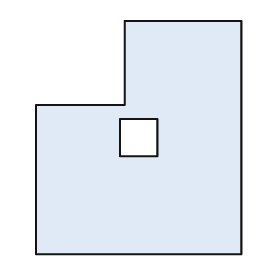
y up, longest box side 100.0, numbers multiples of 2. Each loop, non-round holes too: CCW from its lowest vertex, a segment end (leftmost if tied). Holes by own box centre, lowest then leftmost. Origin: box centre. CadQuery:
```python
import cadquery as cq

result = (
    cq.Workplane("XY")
    .moveTo(-44.0, -50.0)
    .lineTo(44.0, -50.0)
    .lineTo(44.0, 50.0)
    .lineTo(-6.0, 50.0)
    .lineTo(-6.0, 14.0)
    .lineTo(-44.0, 14.0)
    .close()
    .moveTo(-8.0, -8.0)
    .lineTo(8.0, -8.0)
    .lineTo(8.0, 8.0)
    .lineTo(-8.0, 8.0)
    .close()
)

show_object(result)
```